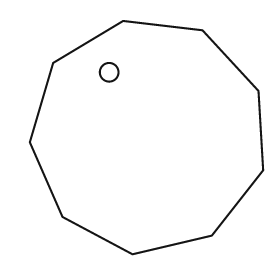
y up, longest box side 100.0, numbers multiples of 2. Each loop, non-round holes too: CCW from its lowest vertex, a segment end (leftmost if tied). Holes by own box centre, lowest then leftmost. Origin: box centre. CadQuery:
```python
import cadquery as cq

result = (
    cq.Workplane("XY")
    .moveTo(-6.0, -50.0)
    .lineTo(28.0, -42.0)
    .lineTo(50.0, -14.0)
    .lineTo(48.0, 20.0)
    .lineTo(24.0, 46.0)
    .lineTo(-10.0, 50.0)
    .lineTo(-40.0, 32.0)
    .lineTo(-50.0, -2.0)
    .lineTo(-36.0, -34.0)
    .close()
    .moveTo(-16.0, 28.0)
    .circle(4.0)
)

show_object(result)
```